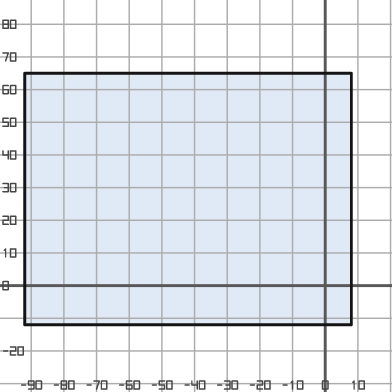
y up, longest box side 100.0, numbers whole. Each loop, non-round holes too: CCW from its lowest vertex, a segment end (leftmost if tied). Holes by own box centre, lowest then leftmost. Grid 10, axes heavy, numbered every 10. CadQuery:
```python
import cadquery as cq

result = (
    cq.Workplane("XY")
    .moveTo(-92.0, -12.0)
    .lineTo(8.0, -12.0)
    .lineTo(8.0, 65.0)
    .lineTo(-92.0, 65.0)
    .close()
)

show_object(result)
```